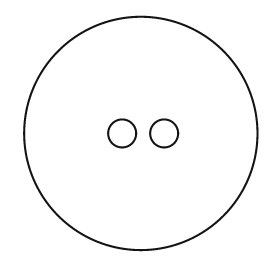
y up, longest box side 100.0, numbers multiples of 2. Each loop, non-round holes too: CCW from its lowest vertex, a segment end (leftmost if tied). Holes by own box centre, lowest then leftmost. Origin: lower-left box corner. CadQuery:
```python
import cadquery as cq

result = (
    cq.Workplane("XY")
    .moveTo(50.0, 50.0)
    .circle(50.0)
    .moveTo(42.0, 50.0)
    .circle(6.0)
    .moveTo(60.0, 50.0)
    .circle(6.0)
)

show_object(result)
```